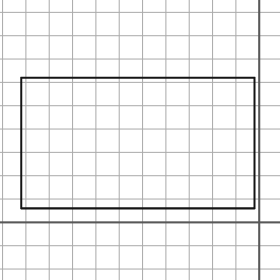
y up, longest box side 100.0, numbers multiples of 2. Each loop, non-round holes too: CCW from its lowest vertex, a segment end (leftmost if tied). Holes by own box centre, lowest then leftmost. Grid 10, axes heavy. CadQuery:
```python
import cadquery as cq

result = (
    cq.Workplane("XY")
    .moveTo(-102.0, 6.0)
    .lineTo(-2.0, 6.0)
    .lineTo(-2.0, 62.0)
    .lineTo(-102.0, 62.0)
    .close()
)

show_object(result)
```